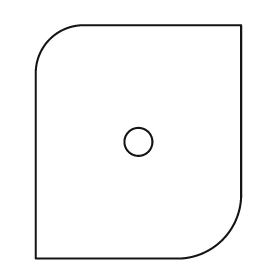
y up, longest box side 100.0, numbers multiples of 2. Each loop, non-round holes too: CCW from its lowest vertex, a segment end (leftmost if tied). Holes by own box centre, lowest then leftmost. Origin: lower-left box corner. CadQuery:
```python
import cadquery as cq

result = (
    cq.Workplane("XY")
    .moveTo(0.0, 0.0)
    .lineTo(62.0, 0.0)
    .threePointArc((80.0, 8.0), (88.0, 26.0))
    .lineTo(88.0, 100.0)
    .lineTo(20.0, 100.0)
    .threePointArc((6.0, 94.0), (0.0, 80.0))
    .close()
    .moveTo(44.0, 50.0)
    .circle(6.0)
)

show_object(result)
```